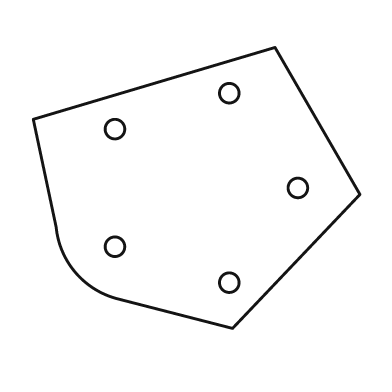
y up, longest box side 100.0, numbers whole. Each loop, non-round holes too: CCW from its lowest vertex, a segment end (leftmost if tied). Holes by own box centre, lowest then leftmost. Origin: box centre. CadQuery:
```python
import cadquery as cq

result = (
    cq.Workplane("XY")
    .moveTo(11.0, -43.0)
    .lineTo(50.0, -2.0)
    .lineTo(24.0, 43.0)
    .lineTo(-50.0, 21.0)
    .lineTo(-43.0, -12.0)
    .threePointArc((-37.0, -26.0), (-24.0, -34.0))
    .close()
    .moveTo(10.0, -29.0)
    .circle(3.0)
    .moveTo(-25.0, -18.0)
    .circle(3.0)
    .moveTo(31.0, 0.0)
    .circle(3.0)
    .moveTo(-25.0, 18.0)
    .circle(3.0)
    .moveTo(10.0, 29.0)
    .circle(3.0)
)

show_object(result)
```